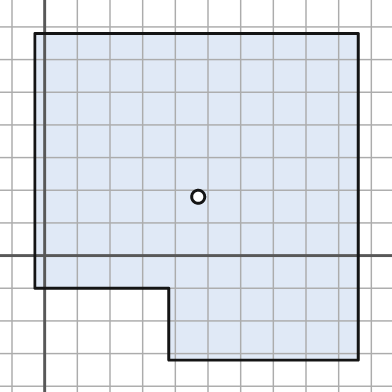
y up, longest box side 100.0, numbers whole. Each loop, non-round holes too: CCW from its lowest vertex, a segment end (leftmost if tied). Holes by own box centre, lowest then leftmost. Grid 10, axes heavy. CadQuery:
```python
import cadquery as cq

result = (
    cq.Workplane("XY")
    .moveTo(38.0, -32.0)
    .lineTo(96.0, -32.0)
    .lineTo(96.0, 68.0)
    .lineTo(-3.0, 68.0)
    .lineTo(-3.0, -10.0)
    .lineTo(38.0, -10.0)
    .close()
    .moveTo(47.0, 18.0)
    .circle(2.0)
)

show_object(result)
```